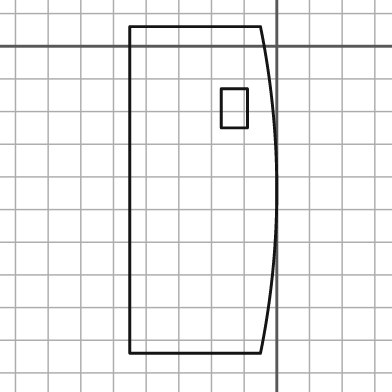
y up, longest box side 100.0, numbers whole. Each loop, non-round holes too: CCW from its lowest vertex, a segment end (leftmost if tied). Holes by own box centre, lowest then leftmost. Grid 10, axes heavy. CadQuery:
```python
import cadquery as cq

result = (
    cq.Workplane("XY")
    .moveTo(-45.0, -94.0)
    .lineTo(-5.0, -94.0)
    .threePointArc((0.0, -44.0), (-5.0, 6.0))
    .lineTo(-45.0, 6.0)
    .close()
    .moveTo(-17.0, -25.0)
    .lineTo(-9.0, -25.0)
    .lineTo(-9.0, -13.0)
    .lineTo(-17.0, -13.0)
    .close()
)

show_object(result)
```